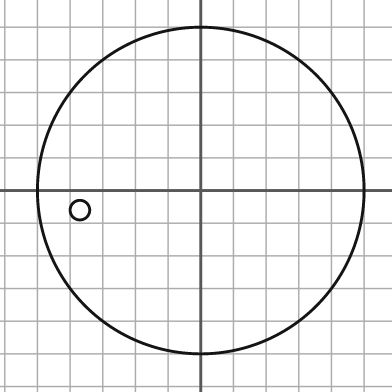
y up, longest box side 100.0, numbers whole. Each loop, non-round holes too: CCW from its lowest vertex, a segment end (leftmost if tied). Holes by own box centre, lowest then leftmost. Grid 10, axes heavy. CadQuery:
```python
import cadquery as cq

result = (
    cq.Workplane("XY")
    .moveTo(0.0, 0.0)
    .circle(50.0)
    .moveTo(-37.0, -6.0)
    .circle(3.0)
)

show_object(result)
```